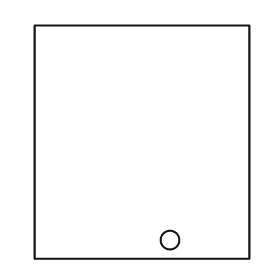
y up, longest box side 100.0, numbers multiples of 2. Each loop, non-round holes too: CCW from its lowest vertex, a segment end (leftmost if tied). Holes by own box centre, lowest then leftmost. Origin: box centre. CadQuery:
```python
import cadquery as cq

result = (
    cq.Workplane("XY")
    .moveTo(-46.0, -50.0)
    .lineTo(46.0, -50.0)
    .lineTo(46.0, 50.0)
    .lineTo(-46.0, 50.0)
    .close()
    .moveTo(12.0, -42.0)
    .circle(4.0)
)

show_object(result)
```